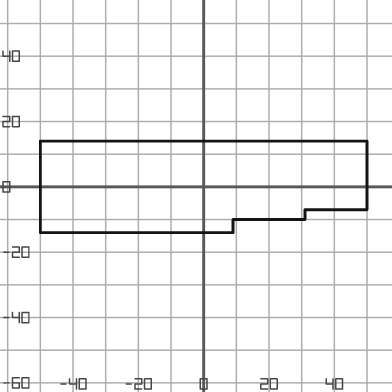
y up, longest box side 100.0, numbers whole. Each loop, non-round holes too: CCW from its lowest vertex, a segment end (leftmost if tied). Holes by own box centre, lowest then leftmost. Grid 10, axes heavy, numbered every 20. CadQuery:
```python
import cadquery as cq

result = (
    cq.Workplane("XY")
    .moveTo(-50.0, -14.0)
    .lineTo(9.0, -14.0)
    .lineTo(9.0, -10.0)
    .lineTo(31.0, -10.0)
    .lineTo(31.0, -7.0)
    .lineTo(50.0, -7.0)
    .lineTo(50.0, 14.0)
    .lineTo(-50.0, 14.0)
    .close()
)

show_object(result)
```